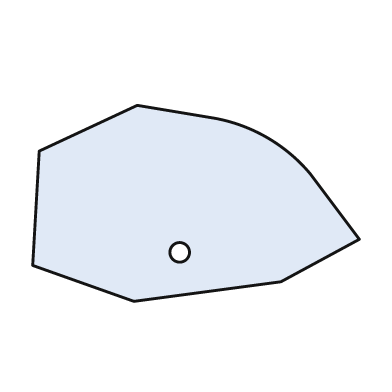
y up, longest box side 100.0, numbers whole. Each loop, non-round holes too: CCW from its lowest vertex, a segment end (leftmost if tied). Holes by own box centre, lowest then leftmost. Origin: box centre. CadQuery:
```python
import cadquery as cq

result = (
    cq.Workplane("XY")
    .moveTo(-19.0, -30.0)
    .lineTo(26.0, -24.0)
    .lineTo(50.0, -11.0)
    .lineTo(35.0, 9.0)
    .threePointArc((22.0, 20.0), (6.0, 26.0))
    .lineTo(-18.0, 30.0)
    .lineTo(-48.0, 16.0)
    .lineTo(-50.0, -19.0)
    .close()
    .moveTo(-5.0, -15.0)
    .circle(3.0)
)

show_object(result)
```